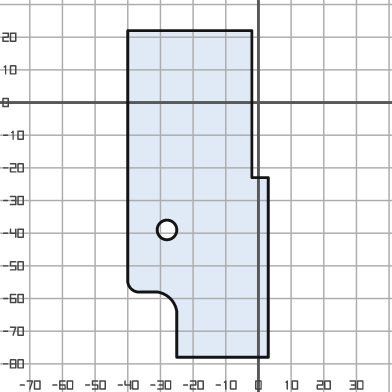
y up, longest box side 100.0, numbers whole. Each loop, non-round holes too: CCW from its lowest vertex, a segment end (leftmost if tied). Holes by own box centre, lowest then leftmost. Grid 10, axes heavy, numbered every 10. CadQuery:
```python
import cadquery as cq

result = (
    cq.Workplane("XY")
    .moveTo(-25.0, -78.0)
    .lineTo(3.0, -78.0)
    .lineTo(3.0, -23.0)
    .lineTo(-2.0, -23.0)
    .lineTo(-2.0, 22.0)
    .lineTo(-40.0, 22.0)
    .lineTo(-40.0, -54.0)
    .threePointArc((-39.0, -57.0), (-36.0, -58.0))
    .lineTo(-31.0, -58.0)
    .threePointArc((-27.0, -60.0), (-25.0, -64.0))
    .close()
    .moveTo(-28.0, -39.0)
    .circle(3.0)
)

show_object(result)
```